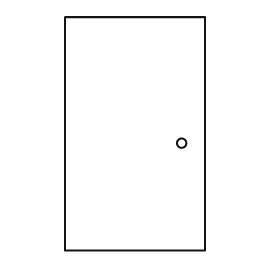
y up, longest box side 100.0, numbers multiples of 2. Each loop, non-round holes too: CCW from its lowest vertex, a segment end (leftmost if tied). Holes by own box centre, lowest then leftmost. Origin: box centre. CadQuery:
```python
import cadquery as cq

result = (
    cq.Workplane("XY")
    .moveTo(-30.0, -50.0)
    .lineTo(30.0, -50.0)
    .lineTo(30.0, 50.0)
    .lineTo(-30.0, 50.0)
    .close()
    .moveTo(20.0, -4.0)
    .circle(2.0)
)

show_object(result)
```